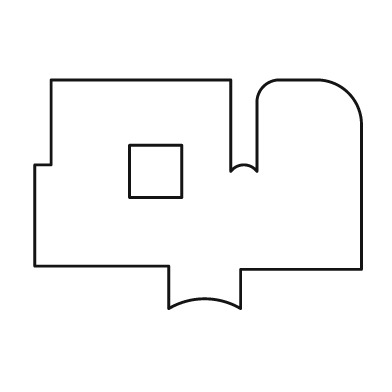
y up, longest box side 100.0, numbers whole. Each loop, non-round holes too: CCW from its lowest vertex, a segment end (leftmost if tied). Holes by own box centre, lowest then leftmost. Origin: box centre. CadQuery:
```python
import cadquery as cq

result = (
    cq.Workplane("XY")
    .moveTo(-9.0, -35.0)
    .threePointArc((2.0, -32.0), (13.0, -35.0))
    .lineTo(13.0, -23.0)
    .lineTo(50.0, -23.0)
    .lineTo(50.0, 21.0)
    .threePointArc((46.0, 31.0), (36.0, 35.0))
    .lineTo(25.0, 35.0)
    .threePointArc((20.0, 33.0), (18.0, 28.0))
    .lineTo(18.0, 7.0)
    .threePointArc((14.0, 9.0), (10.0, 7.0))
    .lineTo(10.0, 35.0)
    .lineTo(-45.0, 35.0)
    .lineTo(-45.0, 9.0)
    .lineTo(-50.0, 9.0)
    .lineTo(-50.0, -22.0)
    .lineTo(-9.0, -22.0)
    .close()
    .moveTo(-21.0, -1.0)
    .lineTo(-5.0, -1.0)
    .lineTo(-5.0, 15.0)
    .lineTo(-21.0, 15.0)
    .close()
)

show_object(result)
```